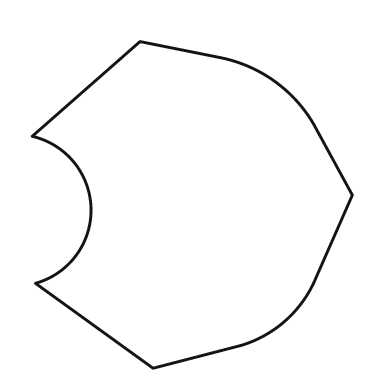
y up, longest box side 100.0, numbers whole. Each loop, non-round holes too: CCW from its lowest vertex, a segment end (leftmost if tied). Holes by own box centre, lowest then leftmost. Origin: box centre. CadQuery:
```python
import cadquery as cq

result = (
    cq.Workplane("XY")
    .moveTo(-12.0, -50.0)
    .lineTo(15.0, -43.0)
    .threePointArc((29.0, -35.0), (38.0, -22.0))
    .lineTo(49.0, 3.0)
    .lineTo(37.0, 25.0)
    .threePointArc((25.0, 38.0), (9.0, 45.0))
    .lineTo(-16.0, 50.0)
    .lineTo(-49.0, 21.0)
    .threePointArc((-31.0, -1.0), (-48.0, -24.0))
    .close()
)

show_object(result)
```